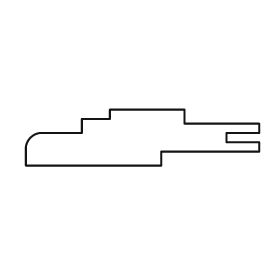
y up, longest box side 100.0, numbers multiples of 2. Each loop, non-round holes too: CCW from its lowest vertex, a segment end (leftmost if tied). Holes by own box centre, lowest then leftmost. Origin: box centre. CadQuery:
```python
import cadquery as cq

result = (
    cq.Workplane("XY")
    .moveTo(-50.0, -12.0)
    .lineTo(8.0, -12.0)
    .lineTo(8.0, -6.0)
    .lineTo(50.0, -6.0)
    .lineTo(50.0, -2.0)
    .lineTo(36.0, -2.0)
    .lineTo(36.0, 2.0)
    .lineTo(50.0, 2.0)
    .lineTo(50.0, 6.0)
    .lineTo(18.0, 6.0)
    .lineTo(18.0, 12.0)
    .lineTo(-14.0, 12.0)
    .lineTo(-14.0, 8.0)
    .lineTo(-26.0, 8.0)
    .lineTo(-26.0, 2.0)
    .lineTo(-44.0, 2.0)
    .threePointArc((-48.0, 0.0), (-50.0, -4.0))
    .close()
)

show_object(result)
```